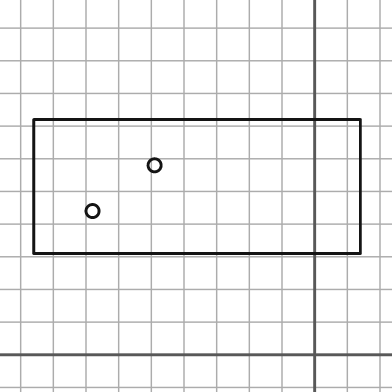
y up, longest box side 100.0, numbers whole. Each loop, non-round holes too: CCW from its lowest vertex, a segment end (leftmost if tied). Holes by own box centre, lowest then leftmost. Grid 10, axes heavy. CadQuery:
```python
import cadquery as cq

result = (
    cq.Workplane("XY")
    .moveTo(-86.0, 31.0)
    .lineTo(14.0, 31.0)
    .lineTo(14.0, 72.0)
    .lineTo(-86.0, 72.0)
    .close()
    .moveTo(-68.0, 44.0)
    .circle(2.0)
    .moveTo(-49.0, 58.0)
    .circle(2.0)
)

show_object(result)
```